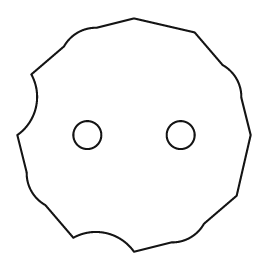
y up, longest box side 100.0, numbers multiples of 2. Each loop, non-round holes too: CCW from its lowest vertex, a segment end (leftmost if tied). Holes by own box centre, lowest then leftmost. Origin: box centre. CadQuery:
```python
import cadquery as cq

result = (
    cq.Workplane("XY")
    .moveTo(0.0, -50.0)
    .lineTo(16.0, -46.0)
    .threePointArc((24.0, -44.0), (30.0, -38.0))
    .lineTo(44.0, -26.0)
    .lineTo(50.0, 0.0)
    .lineTo(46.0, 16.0)
    .threePointArc((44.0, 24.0), (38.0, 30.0))
    .lineTo(26.0, 44.0)
    .lineTo(0.0, 50.0)
    .lineTo(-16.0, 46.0)
    .threePointArc((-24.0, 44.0), (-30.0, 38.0))
    .lineTo(-44.0, 26.0)
    .threePointArc((-42.0, 12.0), (-50.0, 0.0))
    .lineTo(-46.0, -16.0)
    .threePointArc((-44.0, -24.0), (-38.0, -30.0))
    .lineTo(-26.0, -44.0)
    .threePointArc((-12.0, -42.0), (0.0, -50.0))
    .close()
    .moveTo(-20.0, 0.0)
    .circle(6.0)
    .moveTo(20.0, 0.0)
    .circle(6.0)
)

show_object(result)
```